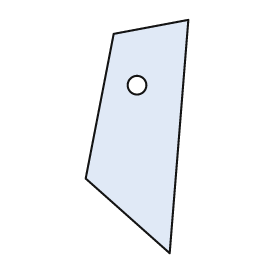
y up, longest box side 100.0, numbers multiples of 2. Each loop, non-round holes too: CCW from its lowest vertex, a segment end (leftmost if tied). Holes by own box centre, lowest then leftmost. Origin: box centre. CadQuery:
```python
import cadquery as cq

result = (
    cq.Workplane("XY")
    .moveTo(14.0, -50.0)
    .lineTo(22.0, 50.0)
    .lineTo(-10.0, 44.0)
    .lineTo(-22.0, -18.0)
    .close()
    .moveTo(0.0, 22.0)
    .circle(4.0)
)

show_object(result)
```